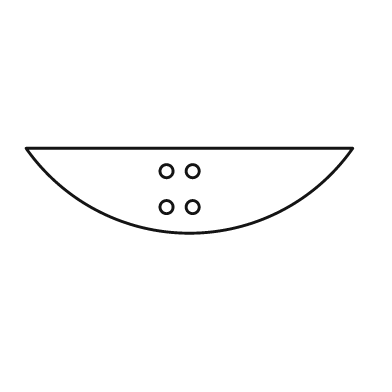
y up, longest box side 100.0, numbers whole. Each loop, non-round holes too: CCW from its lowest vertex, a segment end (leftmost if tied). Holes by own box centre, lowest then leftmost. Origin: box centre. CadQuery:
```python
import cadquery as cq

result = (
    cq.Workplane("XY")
    .moveTo(-50.0, 13.0)
    .threePointArc((0.0, -13.0), (50.0, 13.0))
    .close()
    .moveTo(-7.0, -5.0)
    .circle(2.0)
    .moveTo(1.0, -5.0)
    .circle(2.0)
    .moveTo(-7.0, 6.0)
    .circle(2.0)
    .moveTo(1.0, 6.0)
    .circle(2.0)
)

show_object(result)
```